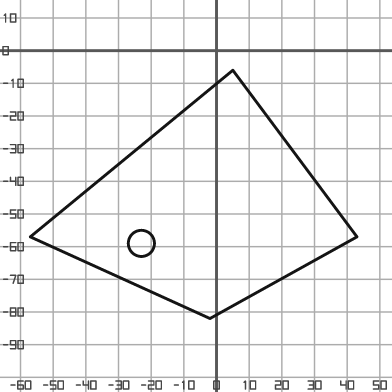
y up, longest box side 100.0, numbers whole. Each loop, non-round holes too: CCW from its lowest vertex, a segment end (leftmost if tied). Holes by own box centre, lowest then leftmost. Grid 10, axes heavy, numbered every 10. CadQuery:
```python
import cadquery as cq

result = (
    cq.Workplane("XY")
    .moveTo(-2.0, -82.0)
    .lineTo(43.0, -57.0)
    .lineTo(5.0, -6.0)
    .lineTo(-57.0, -57.0)
    .close()
    .moveTo(-23.0, -59.0)
    .circle(4.0)
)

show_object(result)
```